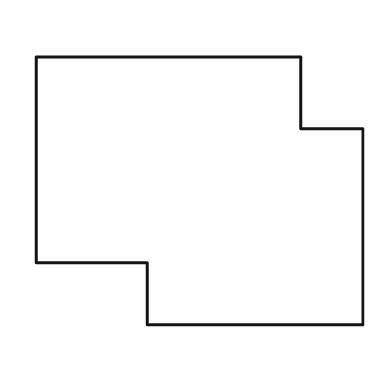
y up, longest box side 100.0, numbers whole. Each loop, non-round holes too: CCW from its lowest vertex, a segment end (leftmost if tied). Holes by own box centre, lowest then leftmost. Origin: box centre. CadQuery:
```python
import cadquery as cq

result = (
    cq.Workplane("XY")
    .moveTo(-16.0, -41.0)
    .lineTo(50.0, -41.0)
    .lineTo(50.0, 19.0)
    .lineTo(31.0, 19.0)
    .lineTo(31.0, 41.0)
    .lineTo(-50.0, 41.0)
    .lineTo(-50.0, -22.0)
    .lineTo(-16.0, -22.0)
    .close()
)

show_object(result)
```